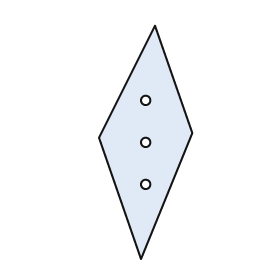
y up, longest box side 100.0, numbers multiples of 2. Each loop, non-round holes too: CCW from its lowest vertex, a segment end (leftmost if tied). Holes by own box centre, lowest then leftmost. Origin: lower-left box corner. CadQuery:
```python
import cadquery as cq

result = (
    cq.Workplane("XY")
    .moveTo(18.0, 0.0)
    .lineTo(40.0, 54.0)
    .lineTo(24.0, 100.0)
    .lineTo(0.0, 52.0)
    .close()
    .moveTo(20.0, 32.0)
    .circle(2.0)
    .moveTo(20.0, 50.0)
    .circle(2.0)
    .moveTo(20.0, 68.0)
    .circle(2.0)
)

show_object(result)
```